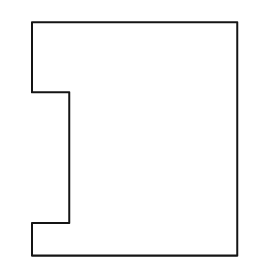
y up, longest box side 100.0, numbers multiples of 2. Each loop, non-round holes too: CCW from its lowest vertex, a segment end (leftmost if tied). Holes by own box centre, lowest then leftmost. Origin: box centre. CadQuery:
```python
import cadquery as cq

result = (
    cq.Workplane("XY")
    .moveTo(-44.0, -50.0)
    .lineTo(44.0, -50.0)
    .lineTo(44.0, 50.0)
    .lineTo(-44.0, 50.0)
    .lineTo(-44.0, 20.0)
    .lineTo(-28.0, 20.0)
    .lineTo(-28.0, -36.0)
    .lineTo(-44.0, -36.0)
    .close()
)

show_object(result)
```